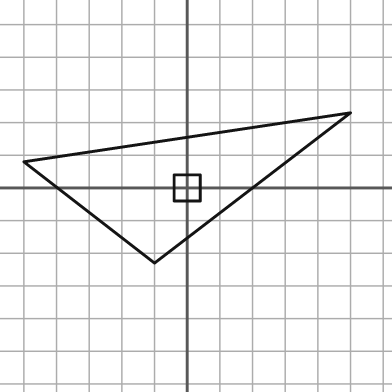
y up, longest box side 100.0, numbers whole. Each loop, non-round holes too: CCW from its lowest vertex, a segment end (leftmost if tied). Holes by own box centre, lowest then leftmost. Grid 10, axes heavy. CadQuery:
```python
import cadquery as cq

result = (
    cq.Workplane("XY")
    .moveTo(-10.0, -23.0)
    .lineTo(50.0, 23.0)
    .lineTo(-50.0, 8.0)
    .close()
    .moveTo(-4.0, -4.0)
    .lineTo(4.0, -4.0)
    .lineTo(4.0, 4.0)
    .lineTo(-4.0, 4.0)
    .close()
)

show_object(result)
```